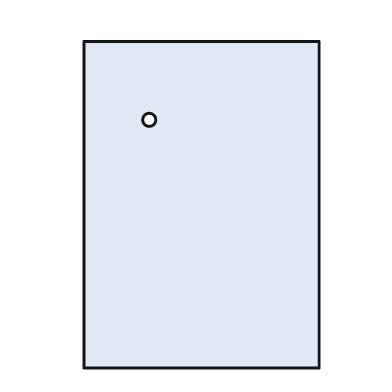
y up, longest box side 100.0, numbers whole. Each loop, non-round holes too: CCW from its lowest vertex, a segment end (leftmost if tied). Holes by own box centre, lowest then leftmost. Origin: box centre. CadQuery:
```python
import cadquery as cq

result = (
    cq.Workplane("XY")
    .moveTo(-36.0, -50.0)
    .lineTo(36.0, -50.0)
    .lineTo(36.0, 50.0)
    .lineTo(-36.0, 50.0)
    .close()
    .moveTo(-16.0, 26.0)
    .circle(2.0)
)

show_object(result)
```